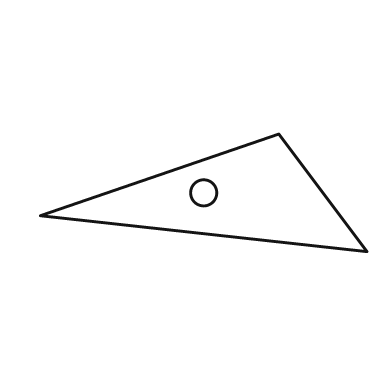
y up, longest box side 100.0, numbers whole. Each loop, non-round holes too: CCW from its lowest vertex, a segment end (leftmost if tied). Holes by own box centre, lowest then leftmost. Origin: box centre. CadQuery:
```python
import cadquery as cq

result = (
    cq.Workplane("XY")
    .moveTo(50.0, -18.0)
    .lineTo(23.0, 18.0)
    .lineTo(-50.0, -7.0)
    .close()
    .moveTo(0.0, 0.0)
    .circle(4.0)
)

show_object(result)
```